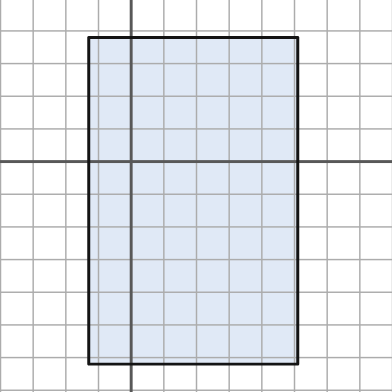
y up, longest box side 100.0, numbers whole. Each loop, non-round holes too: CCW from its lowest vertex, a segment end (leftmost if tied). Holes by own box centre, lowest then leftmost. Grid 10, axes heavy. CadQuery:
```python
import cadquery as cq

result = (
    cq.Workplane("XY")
    .moveTo(-13.0, -62.0)
    .lineTo(51.0, -62.0)
    .lineTo(51.0, 38.0)
    .lineTo(-13.0, 38.0)
    .close()
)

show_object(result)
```